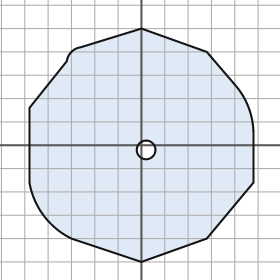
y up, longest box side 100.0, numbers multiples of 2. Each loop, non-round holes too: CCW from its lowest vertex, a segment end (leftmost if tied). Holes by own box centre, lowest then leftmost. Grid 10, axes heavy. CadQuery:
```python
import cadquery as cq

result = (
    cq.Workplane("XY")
    .moveTo(0.0, -50.0)
    .lineTo(28.0, -40.0)
    .lineTo(48.0, -16.0)
    .lineTo(48.0, 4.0)
    .threePointArc((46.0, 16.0), (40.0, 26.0))
    .lineTo(28.0, 40.0)
    .lineTo(0.0, 50.0)
    .lineTo(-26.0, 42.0)
    .threePointArc((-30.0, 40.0), (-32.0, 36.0))
    .lineTo(-48.0, 16.0)
    .lineTo(-48.0, -16.0)
    .threePointArc((-42.0, -30.0), (-30.0, -40.0))
    .close()
    .moveTo(2.0, -2.0)
    .circle(4.0)
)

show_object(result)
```